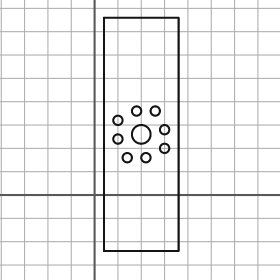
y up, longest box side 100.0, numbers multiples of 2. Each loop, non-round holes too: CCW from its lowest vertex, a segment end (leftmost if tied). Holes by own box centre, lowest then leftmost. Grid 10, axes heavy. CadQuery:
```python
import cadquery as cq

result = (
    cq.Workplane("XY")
    .moveTo(4.0, -24.0)
    .lineTo(36.0, -24.0)
    .lineTo(36.0, 76.0)
    .lineTo(4.0, 76.0)
    .close()
    .moveTo(14.0, 16.0)
    .circle(2.0)
    .moveTo(22.0, 16.0)
    .circle(2.0)
    .moveTo(30.0, 20.0)
    .circle(2.0)
    .moveTo(10.0, 24.0)
    .circle(2.0)
    .moveTo(20.0, 26.0)
    .circle(4.0)
    .moveTo(30.0, 28.0)
    .circle(2.0)
    .moveTo(10.0, 32.0)
    .circle(2.0)
    .moveTo(18.0, 36.0)
    .circle(2.0)
    .moveTo(26.0, 36.0)
    .circle(2.0)
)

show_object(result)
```